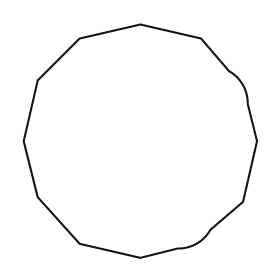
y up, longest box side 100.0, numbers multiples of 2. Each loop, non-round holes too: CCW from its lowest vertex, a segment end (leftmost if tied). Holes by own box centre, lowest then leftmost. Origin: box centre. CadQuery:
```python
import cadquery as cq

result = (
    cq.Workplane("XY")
    .moveTo(0.0, -50.0)
    .lineTo(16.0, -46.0)
    .threePointArc((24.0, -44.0), (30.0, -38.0))
    .lineTo(44.0, -26.0)
    .lineTo(50.0, 0.0)
    .lineTo(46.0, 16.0)
    .threePointArc((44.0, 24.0), (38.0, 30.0))
    .lineTo(26.0, 44.0)
    .lineTo(0.0, 50.0)
    .lineTo(-26.0, 44.0)
    .lineTo(-44.0, 26.0)
    .lineTo(-50.0, 0.0)
    .lineTo(-44.0, -24.0)
    .lineTo(-26.0, -44.0)
    .close()
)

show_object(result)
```